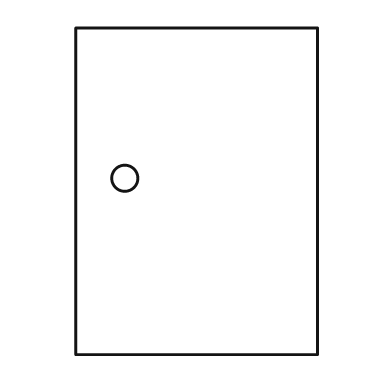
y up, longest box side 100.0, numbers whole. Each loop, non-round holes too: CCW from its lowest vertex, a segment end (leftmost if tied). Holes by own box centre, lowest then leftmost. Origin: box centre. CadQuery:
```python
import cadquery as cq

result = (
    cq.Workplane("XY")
    .moveTo(-37.0, -50.0)
    .lineTo(37.0, -50.0)
    .lineTo(37.0, 50.0)
    .lineTo(-37.0, 50.0)
    .close()
    .moveTo(-22.0, 4.0)
    .circle(4.0)
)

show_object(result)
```